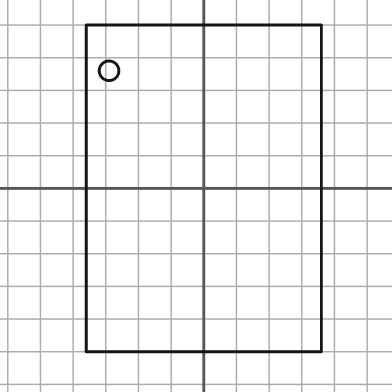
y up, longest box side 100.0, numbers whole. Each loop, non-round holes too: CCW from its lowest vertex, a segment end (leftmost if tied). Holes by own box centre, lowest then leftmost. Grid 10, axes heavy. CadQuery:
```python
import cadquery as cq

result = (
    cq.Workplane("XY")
    .moveTo(-36.0, -50.0)
    .lineTo(36.0, -50.0)
    .lineTo(36.0, 50.0)
    .lineTo(-36.0, 50.0)
    .close()
    .moveTo(-29.0, 36.0)
    .circle(3.0)
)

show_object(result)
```